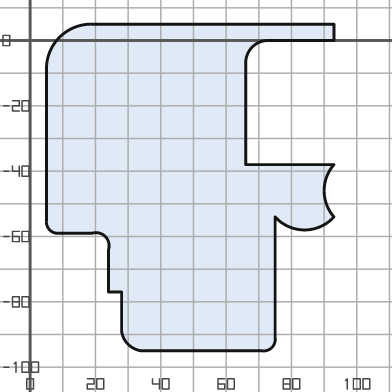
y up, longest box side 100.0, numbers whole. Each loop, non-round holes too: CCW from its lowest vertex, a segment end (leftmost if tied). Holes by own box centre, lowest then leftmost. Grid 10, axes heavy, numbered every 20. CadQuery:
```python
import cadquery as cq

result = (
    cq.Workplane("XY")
    .moveTo(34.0, -95.0)
    .lineTo(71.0, -95.0)
    .threePointArc((74.0, -94.0), (75.0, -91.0))
    .lineTo(75.0, -54.0)
    .threePointArc((84.0, -58.0), (93.0, -54.0))
    .threePointArc((90.0, -46.0), (93.0, -38.0))
    .lineTo(66.0, -38.0)
    .lineTo(66.0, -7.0)
    .threePointArc((68.0, -2.0), (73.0, 0.0))
    .lineTo(93.0, 0.0)
    .lineTo(93.0, 5.0)
    .lineTo(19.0, 5.0)
    .threePointArc((9.0, 1.0), (5.0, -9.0))
    .lineTo(5.0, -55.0)
    .threePointArc((6.0, -58.0), (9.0, -59.0))
    .lineTo(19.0, -59.0)
    .threePointArc((23.0, -60.0), (24.0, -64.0))
    .lineTo(24.0, -77.0)
    .lineTo(28.0, -77.0)
    .lineTo(28.0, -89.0)
    .threePointArc((30.0, -93.0), (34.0, -95.0))
    .close()
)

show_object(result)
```